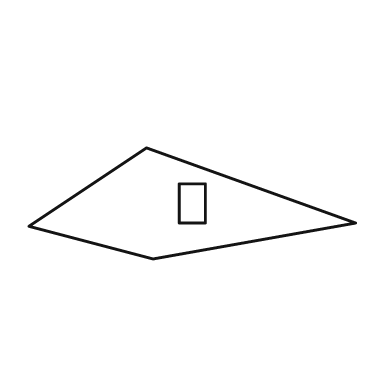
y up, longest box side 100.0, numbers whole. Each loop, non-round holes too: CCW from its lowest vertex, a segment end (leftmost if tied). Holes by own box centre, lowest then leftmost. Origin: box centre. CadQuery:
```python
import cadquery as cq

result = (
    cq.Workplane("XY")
    .moveTo(-12.0, -17.0)
    .lineTo(50.0, -6.0)
    .lineTo(-14.0, 17.0)
    .lineTo(-50.0, -7.0)
    .close()
    .moveTo(-4.0, -6.0)
    .lineTo(4.0, -6.0)
    .lineTo(4.0, 6.0)
    .lineTo(-4.0, 6.0)
    .close()
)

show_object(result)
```